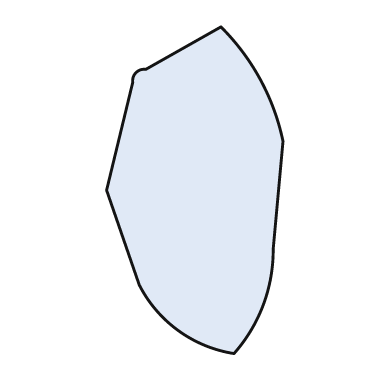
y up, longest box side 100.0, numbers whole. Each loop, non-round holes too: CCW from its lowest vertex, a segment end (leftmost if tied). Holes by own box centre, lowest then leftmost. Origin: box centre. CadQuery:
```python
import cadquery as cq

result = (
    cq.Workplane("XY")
    .moveTo(12.0, -50.0)
    .threePointArc((21.0, -35.0), (24.0, -18.0))
    .lineTo(27.0, 15.0)
    .threePointArc((20.0, 34.0), (8.0, 50.0))
    .lineTo(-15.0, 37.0)
    .threePointArc((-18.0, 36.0), (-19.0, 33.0))
    .lineTo(-27.0, 0.0)
    .lineTo(-17.0, -29.0)
    .threePointArc((-5.0, -43.0), (12.0, -50.0))
    .close()
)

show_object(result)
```